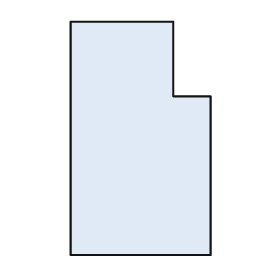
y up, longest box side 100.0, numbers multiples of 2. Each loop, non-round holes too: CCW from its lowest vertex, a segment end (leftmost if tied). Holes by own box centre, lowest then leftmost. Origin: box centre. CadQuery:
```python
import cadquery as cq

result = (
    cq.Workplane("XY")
    .moveTo(-30.0, -50.0)
    .lineTo(30.0, -50.0)
    .lineTo(30.0, 18.0)
    .lineTo(14.0, 18.0)
    .lineTo(14.0, 50.0)
    .lineTo(-30.0, 50.0)
    .close()
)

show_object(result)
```